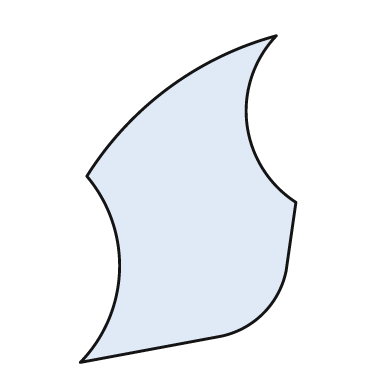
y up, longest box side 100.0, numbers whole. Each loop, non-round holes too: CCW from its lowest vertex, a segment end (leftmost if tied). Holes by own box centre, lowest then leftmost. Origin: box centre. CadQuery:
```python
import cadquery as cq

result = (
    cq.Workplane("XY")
    .moveTo(-33.0, -50.0)
    .lineTo(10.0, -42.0)
    .threePointArc((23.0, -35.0), (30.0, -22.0))
    .lineTo(33.0, -1.0)
    .threePointArc((18.0, 23.0), (27.0, 50.0))
    .threePointArc((-6.0, 34.0), (-31.0, 7.0))
    .threePointArc((-21.0, -22.0), (-33.0, -50.0))
    .close()
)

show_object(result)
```